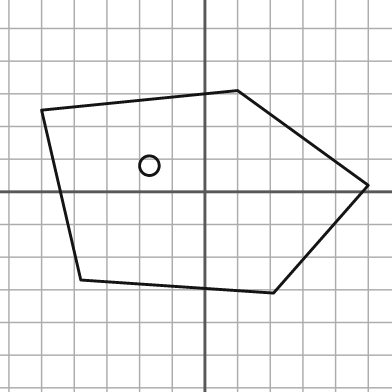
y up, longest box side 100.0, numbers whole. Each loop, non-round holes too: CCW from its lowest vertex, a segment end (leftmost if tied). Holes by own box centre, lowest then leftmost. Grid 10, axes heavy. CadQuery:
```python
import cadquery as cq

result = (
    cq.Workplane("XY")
    .moveTo(21.0, -31.0)
    .lineTo(50.0, 2.0)
    .lineTo(10.0, 31.0)
    .lineTo(-50.0, 25.0)
    .lineTo(-38.0, -27.0)
    .close()
    .moveTo(-17.0, 8.0)
    .circle(3.0)
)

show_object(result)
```